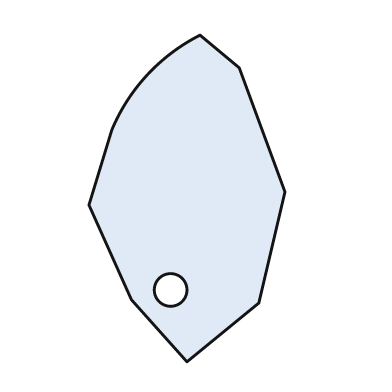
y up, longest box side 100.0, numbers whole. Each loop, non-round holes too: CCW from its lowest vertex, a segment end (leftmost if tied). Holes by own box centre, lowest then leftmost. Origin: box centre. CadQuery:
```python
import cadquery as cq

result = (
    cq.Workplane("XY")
    .moveTo(0.0, -50.0)
    .lineTo(22.0, -32.0)
    .lineTo(30.0, 2.0)
    .lineTo(16.0, 40.0)
    .lineTo(4.0, 50.0)
    .threePointArc((-12.0, 38.0), (-23.0, 21.0))
    .lineTo(-30.0, -2.0)
    .lineTo(-17.0, -31.0)
    .close()
    .moveTo(-5.0, -28.0)
    .circle(5.0)
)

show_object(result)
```